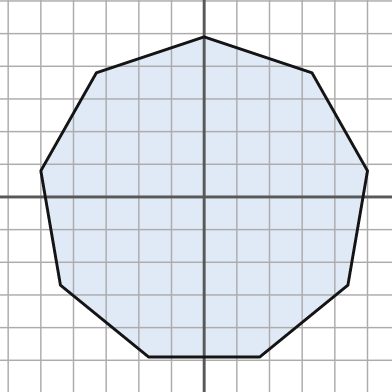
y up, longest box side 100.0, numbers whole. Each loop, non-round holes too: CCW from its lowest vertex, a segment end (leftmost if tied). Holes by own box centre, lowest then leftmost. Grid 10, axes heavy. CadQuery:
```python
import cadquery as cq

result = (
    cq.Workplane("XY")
    .moveTo(-17.0, -49.0)
    .lineTo(17.0, -49.0)
    .lineTo(44.0, -27.0)
    .lineTo(50.0, 8.0)
    .lineTo(33.0, 38.0)
    .lineTo(0.0, 49.0)
    .lineTo(-33.0, 38.0)
    .lineTo(-50.0, 8.0)
    .lineTo(-44.0, -27.0)
    .close()
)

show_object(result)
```